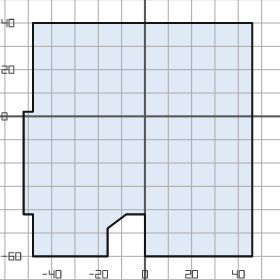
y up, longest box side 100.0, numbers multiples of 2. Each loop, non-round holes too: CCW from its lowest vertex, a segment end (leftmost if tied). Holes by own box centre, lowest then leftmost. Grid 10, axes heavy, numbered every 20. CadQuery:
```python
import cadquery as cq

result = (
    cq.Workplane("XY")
    .moveTo(-48.0, -60.0)
    .lineTo(-16.0, -60.0)
    .lineTo(-16.0, -48.0)
    .lineTo(-8.0, -42.0)
    .lineTo(0.0, -42.0)
    .lineTo(0.0, -60.0)
    .lineTo(46.0, -60.0)
    .lineTo(46.0, 40.0)
    .lineTo(-48.0, 40.0)
    .lineTo(-48.0, 2.0)
    .lineTo(-52.0, 2.0)
    .lineTo(-52.0, -42.0)
    .lineTo(-48.0, -42.0)
    .close()
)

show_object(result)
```